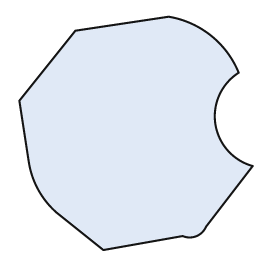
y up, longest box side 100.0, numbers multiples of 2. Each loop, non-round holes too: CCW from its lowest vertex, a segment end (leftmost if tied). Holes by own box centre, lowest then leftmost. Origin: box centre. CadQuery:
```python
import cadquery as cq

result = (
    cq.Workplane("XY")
    .moveTo(-14.0, -50.0)
    .lineTo(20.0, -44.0)
    .threePointArc((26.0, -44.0), (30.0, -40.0))
    .lineTo(50.0, -14.0)
    .threePointArc((34.0, 4.0), (44.0, 26.0))
    .threePointArc((32.0, 42.0), (14.0, 50.0))
    .lineTo(-26.0, 44.0)
    .lineTo(-50.0, 14.0)
    .lineTo(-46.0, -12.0)
    .threePointArc((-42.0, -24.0), (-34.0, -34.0))
    .close()
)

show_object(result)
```